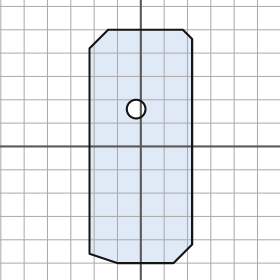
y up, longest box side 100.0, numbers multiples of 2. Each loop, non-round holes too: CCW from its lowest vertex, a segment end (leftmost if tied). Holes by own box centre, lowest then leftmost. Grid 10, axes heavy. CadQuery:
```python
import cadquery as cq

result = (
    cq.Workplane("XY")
    .moveTo(-10.0, -50.0)
    .lineTo(14.0, -50.0)
    .lineTo(22.0, -42.0)
    .lineTo(22.0, 46.0)
    .lineTo(18.0, 50.0)
    .lineTo(-14.0, 50.0)
    .lineTo(-22.0, 42.0)
    .lineTo(-22.0, -46.0)
    .close()
    .moveTo(-2.0, 16.0)
    .circle(4.0)
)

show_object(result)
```